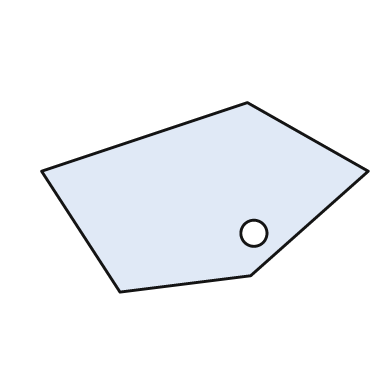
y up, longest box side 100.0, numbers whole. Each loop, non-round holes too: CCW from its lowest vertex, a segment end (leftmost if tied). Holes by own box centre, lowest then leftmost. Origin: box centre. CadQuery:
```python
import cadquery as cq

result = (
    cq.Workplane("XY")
    .moveTo(-26.0, -29.0)
    .lineTo(14.0, -24.0)
    .lineTo(50.0, 8.0)
    .lineTo(13.0, 29.0)
    .lineTo(-50.0, 8.0)
    .close()
    .moveTo(15.0, -11.0)
    .circle(4.0)
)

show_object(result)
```